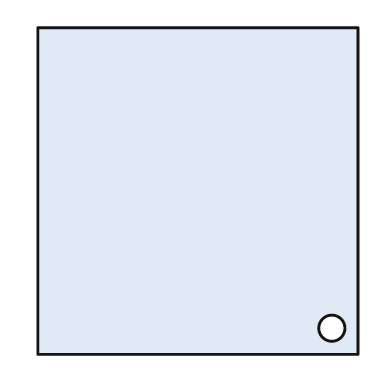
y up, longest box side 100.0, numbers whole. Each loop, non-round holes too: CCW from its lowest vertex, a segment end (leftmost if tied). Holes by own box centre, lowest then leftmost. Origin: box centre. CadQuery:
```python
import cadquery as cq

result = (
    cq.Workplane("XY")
    .moveTo(-49.0, -50.0)
    .lineTo(49.0, -50.0)
    .lineTo(49.0, 50.0)
    .lineTo(-49.0, 50.0)
    .close()
    .moveTo(41.0, -42.0)
    .circle(4.0)
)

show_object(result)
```